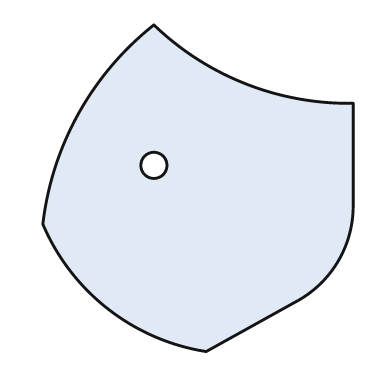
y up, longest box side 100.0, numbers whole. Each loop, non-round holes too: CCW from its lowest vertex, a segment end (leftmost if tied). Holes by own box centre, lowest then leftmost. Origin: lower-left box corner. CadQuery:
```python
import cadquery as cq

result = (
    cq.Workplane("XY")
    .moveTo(50.0, 0.0)
    .lineTo(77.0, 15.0)
    .threePointArc((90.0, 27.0), (95.0, 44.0))
    .lineTo(95.0, 76.0)
    .threePointArc((62.0, 82.0), (34.0, 100.0))
    .threePointArc((11.0, 73.0), (0.0, 39.0))
    .threePointArc((20.0, 13.0), (50.0, 0.0))
    .close()
    .moveTo(34.0, 57.0)
    .circle(4.0)
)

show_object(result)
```